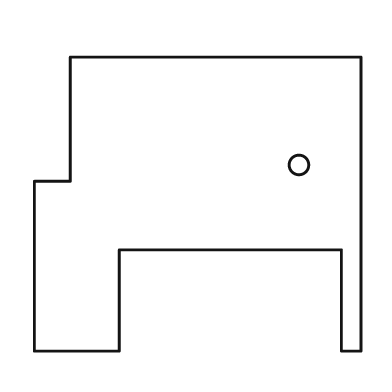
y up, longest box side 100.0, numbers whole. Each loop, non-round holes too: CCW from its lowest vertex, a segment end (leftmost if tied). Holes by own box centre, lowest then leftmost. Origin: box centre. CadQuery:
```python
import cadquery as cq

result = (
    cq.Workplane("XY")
    .moveTo(-50.0, -45.0)
    .lineTo(-24.0, -45.0)
    .lineTo(-24.0, -14.0)
    .lineTo(44.0, -14.0)
    .lineTo(44.0, -45.0)
    .lineTo(50.0, -45.0)
    .lineTo(50.0, 45.0)
    .lineTo(-39.0, 45.0)
    .lineTo(-39.0, 7.0)
    .lineTo(-50.0, 7.0)
    .close()
    .moveTo(31.0, 12.0)
    .circle(3.0)
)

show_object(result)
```